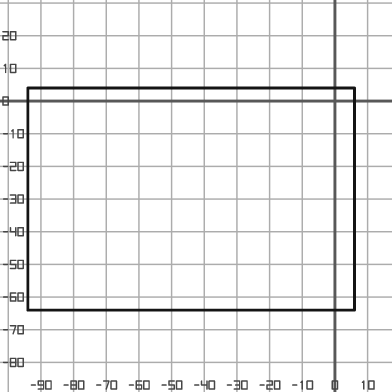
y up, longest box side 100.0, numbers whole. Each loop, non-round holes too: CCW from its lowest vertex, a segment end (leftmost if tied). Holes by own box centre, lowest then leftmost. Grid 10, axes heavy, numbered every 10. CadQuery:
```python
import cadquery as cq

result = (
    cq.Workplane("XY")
    .moveTo(-94.0, -64.0)
    .lineTo(6.0, -64.0)
    .lineTo(6.0, 4.0)
    .lineTo(-94.0, 4.0)
    .close()
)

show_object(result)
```